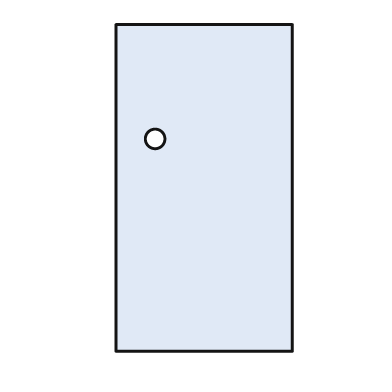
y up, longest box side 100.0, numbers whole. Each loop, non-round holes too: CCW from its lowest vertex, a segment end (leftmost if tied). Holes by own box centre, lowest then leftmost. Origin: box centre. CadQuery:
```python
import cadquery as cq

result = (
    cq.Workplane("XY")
    .moveTo(-27.0, -50.0)
    .lineTo(27.0, -50.0)
    .lineTo(27.0, 50.0)
    .lineTo(-27.0, 50.0)
    .close()
    .moveTo(-15.0, 15.0)
    .circle(3.0)
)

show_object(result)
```